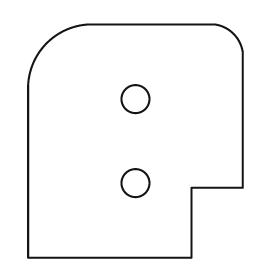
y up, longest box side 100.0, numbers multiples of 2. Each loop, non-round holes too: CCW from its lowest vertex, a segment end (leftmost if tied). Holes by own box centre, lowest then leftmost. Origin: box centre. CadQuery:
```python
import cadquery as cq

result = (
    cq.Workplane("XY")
    .moveTo(-46.0, -50.0)
    .lineTo(24.0, -50.0)
    .lineTo(24.0, -20.0)
    .lineTo(46.0, -20.0)
    .lineTo(46.0, 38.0)
    .threePointArc((42.0, 46.0), (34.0, 50.0))
    .lineTo(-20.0, 50.0)
    .threePointArc((-38.0, 42.0), (-46.0, 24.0))
    .close()
    .moveTo(0.0, -18.0)
    .circle(6.0)
    .moveTo(0.0, 18.0)
    .circle(6.0)
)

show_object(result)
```